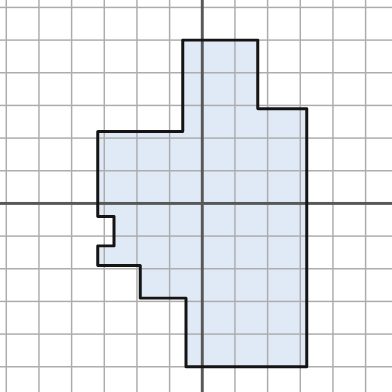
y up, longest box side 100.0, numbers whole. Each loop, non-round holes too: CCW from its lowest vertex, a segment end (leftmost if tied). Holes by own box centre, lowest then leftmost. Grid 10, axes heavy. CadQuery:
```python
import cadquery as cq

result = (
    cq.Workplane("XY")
    .moveTo(-5.0, -50.0)
    .lineTo(32.0, -50.0)
    .lineTo(32.0, 29.0)
    .lineTo(17.0, 29.0)
    .lineTo(17.0, 50.0)
    .lineTo(-6.0, 50.0)
    .lineTo(-6.0, 22.0)
    .lineTo(-32.0, 22.0)
    .lineTo(-32.0, -4.0)
    .lineTo(-27.0, -4.0)
    .lineTo(-27.0, -13.0)
    .lineTo(-32.0, -13.0)
    .lineTo(-32.0, -19.0)
    .lineTo(-19.0, -19.0)
    .lineTo(-19.0, -29.0)
    .lineTo(-5.0, -29.0)
    .close()
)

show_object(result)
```